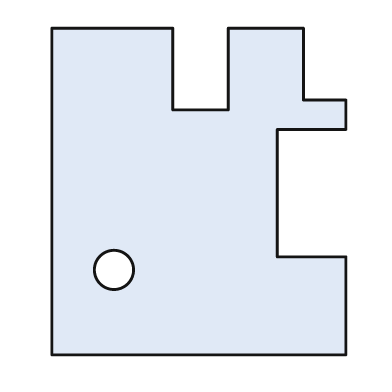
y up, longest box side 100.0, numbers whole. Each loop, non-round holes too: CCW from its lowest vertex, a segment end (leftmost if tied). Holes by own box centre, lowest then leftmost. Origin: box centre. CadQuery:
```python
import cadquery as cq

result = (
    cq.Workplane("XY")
    .moveTo(-45.0, -50.0)
    .lineTo(45.0, -50.0)
    .lineTo(45.0, -20.0)
    .lineTo(24.0, -20.0)
    .lineTo(24.0, 19.0)
    .lineTo(45.0, 19.0)
    .lineTo(45.0, 28.0)
    .lineTo(32.0, 28.0)
    .lineTo(32.0, 50.0)
    .lineTo(9.0, 50.0)
    .lineTo(9.0, 25.0)
    .lineTo(-8.0, 25.0)
    .lineTo(-8.0, 50.0)
    .lineTo(-45.0, 50.0)
    .close()
    .moveTo(-26.0, -24.0)
    .circle(6.0)
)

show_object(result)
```